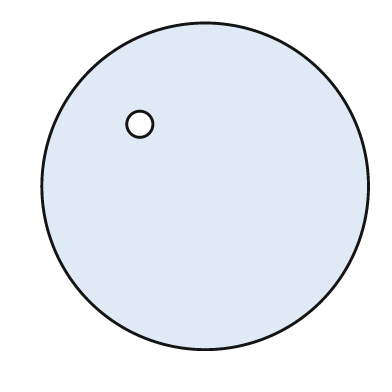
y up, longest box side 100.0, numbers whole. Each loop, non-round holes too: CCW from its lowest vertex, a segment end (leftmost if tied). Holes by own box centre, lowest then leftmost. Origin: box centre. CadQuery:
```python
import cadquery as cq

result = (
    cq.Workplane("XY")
    .moveTo(0.0, 0.0)
    .circle(50.0)
    .moveTo(-20.0, 19.0)
    .circle(4.0)
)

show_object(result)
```